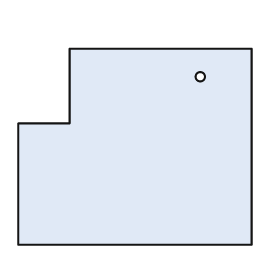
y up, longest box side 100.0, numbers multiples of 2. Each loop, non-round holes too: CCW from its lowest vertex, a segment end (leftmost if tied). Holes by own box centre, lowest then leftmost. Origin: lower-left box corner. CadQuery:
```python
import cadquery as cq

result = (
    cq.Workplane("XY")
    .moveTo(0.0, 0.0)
    .lineTo(100.0, 0.0)
    .lineTo(100.0, 84.0)
    .lineTo(22.0, 84.0)
    .lineTo(22.0, 52.0)
    .lineTo(0.0, 52.0)
    .close()
    .moveTo(78.0, 72.0)
    .circle(2.0)
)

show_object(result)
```